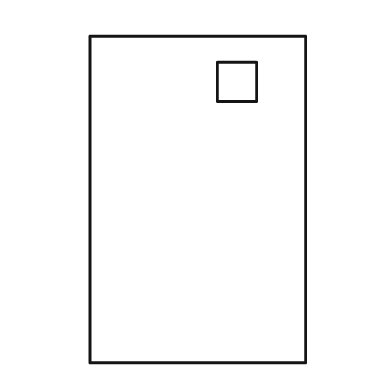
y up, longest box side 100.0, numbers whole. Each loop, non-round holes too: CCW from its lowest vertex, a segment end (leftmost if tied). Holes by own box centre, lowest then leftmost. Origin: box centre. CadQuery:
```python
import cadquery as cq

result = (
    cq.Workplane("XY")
    .moveTo(-33.0, -50.0)
    .lineTo(33.0, -50.0)
    .lineTo(33.0, 50.0)
    .lineTo(-33.0, 50.0)
    .close()
    .moveTo(6.0, 30.0)
    .lineTo(18.0, 30.0)
    .lineTo(18.0, 42.0)
    .lineTo(6.0, 42.0)
    .close()
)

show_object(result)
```